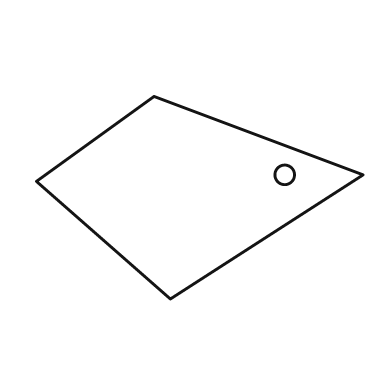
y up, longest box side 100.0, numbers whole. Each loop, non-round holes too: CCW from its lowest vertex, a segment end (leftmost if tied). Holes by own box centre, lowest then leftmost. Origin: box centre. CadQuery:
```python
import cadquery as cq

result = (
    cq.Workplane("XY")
    .moveTo(-9.0, -31.0)
    .lineTo(50.0, 7.0)
    .lineTo(-14.0, 31.0)
    .lineTo(-50.0, 5.0)
    .close()
    .moveTo(26.0, 7.0)
    .circle(3.0)
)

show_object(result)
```